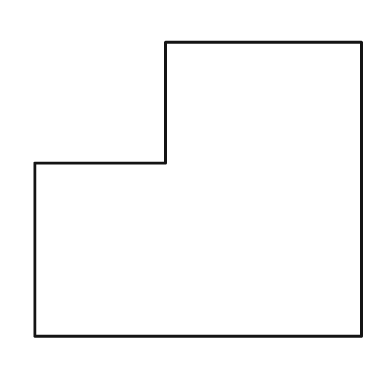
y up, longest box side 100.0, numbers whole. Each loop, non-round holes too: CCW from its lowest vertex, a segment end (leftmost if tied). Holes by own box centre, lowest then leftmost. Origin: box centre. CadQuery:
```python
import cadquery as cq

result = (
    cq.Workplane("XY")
    .moveTo(-50.0, -45.0)
    .lineTo(50.0, -45.0)
    .lineTo(50.0, 45.0)
    .lineTo(-10.0, 45.0)
    .lineTo(-10.0, 8.0)
    .lineTo(-50.0, 8.0)
    .close()
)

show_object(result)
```